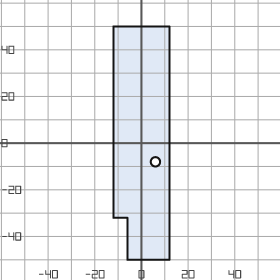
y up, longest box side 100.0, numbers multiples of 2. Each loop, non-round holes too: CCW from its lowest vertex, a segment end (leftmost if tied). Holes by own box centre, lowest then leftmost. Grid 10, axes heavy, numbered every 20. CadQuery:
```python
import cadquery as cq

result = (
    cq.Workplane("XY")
    .moveTo(-6.0, -50.0)
    .lineTo(12.0, -50.0)
    .lineTo(12.0, 50.0)
    .lineTo(-12.0, 50.0)
    .lineTo(-12.0, -32.0)
    .lineTo(-6.0, -32.0)
    .close()
    .moveTo(6.0, -8.0)
    .circle(2.0)
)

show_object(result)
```